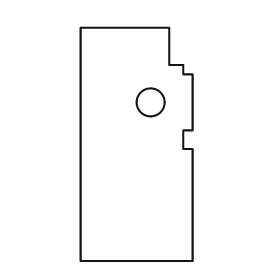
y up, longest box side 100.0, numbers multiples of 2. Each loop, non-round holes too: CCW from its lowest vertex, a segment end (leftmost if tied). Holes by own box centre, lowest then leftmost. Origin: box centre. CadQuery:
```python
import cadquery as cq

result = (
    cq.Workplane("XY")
    .moveTo(-24.0, -50.0)
    .lineTo(24.0, -50.0)
    .lineTo(24.0, -2.0)
    .lineTo(20.0, -2.0)
    .lineTo(20.0, 6.0)
    .lineTo(24.0, 6.0)
    .lineTo(24.0, 30.0)
    .lineTo(20.0, 30.0)
    .lineTo(20.0, 34.0)
    .lineTo(14.0, 34.0)
    .lineTo(14.0, 50.0)
    .lineTo(-24.0, 50.0)
    .close()
    .moveTo(6.0, 18.0)
    .circle(6.0)
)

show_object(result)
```